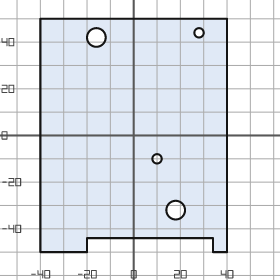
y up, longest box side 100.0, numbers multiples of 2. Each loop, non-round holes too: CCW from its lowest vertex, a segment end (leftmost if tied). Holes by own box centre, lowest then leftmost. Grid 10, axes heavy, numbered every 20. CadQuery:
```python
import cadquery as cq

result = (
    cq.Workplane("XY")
    .moveTo(-40.0, -50.0)
    .lineTo(-20.0, -50.0)
    .lineTo(-20.0, -44.0)
    .lineTo(34.0, -44.0)
    .lineTo(34.0, -50.0)
    .lineTo(40.0, -50.0)
    .lineTo(40.0, 50.0)
    .lineTo(-40.0, 50.0)
    .close()
    .moveTo(18.0, -32.0)
    .circle(4.0)
    .moveTo(10.0, -10.0)
    .circle(2.0)
    .moveTo(-16.0, 42.0)
    .circle(4.0)
    .moveTo(28.0, 44.0)
    .circle(2.0)
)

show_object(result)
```